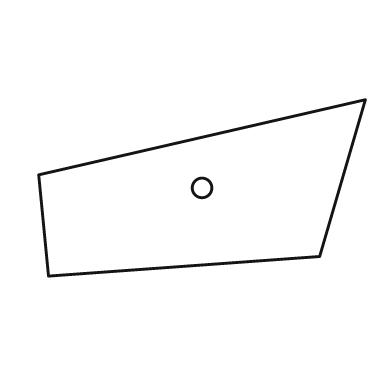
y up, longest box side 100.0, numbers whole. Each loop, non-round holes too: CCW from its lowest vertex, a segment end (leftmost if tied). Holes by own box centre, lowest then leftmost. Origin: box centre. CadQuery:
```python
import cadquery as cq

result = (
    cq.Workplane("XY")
    .moveTo(-47.0, -27.0)
    .lineTo(36.0, -21.0)
    .lineTo(50.0, 27.0)
    .lineTo(-50.0, 4.0)
    .close()
    .moveTo(0.0, 0.0)
    .circle(3.0)
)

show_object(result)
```